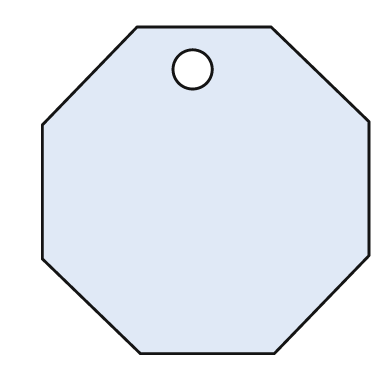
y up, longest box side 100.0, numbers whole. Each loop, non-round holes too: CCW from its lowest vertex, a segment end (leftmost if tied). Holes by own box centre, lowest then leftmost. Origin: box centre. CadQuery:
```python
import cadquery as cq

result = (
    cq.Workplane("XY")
    .moveTo(-20.0, -50.0)
    .lineTo(21.0, -50.0)
    .lineTo(50.0, -20.0)
    .lineTo(50.0, 21.0)
    .lineTo(20.0, 50.0)
    .lineTo(-21.0, 50.0)
    .lineTo(-50.0, 20.0)
    .lineTo(-50.0, -21.0)
    .close()
    .moveTo(-4.0, 37.0)
    .circle(6.0)
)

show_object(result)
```